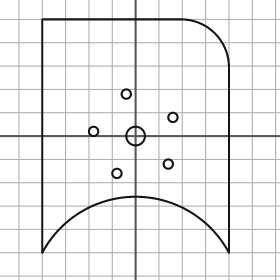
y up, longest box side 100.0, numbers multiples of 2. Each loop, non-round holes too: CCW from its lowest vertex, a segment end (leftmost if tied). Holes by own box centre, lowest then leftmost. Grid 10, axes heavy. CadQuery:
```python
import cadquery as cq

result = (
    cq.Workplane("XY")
    .moveTo(-40.0, -50.0)
    .threePointArc((0.0, -26.0), (40.0, -50.0))
    .lineTo(40.0, 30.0)
    .threePointArc((34.0, 44.0), (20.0, 50.0))
    .lineTo(-40.0, 50.0)
    .close()
    .moveTo(-8.0, -16.0)
    .circle(2.0)
    .moveTo(14.0, -12.0)
    .circle(2.0)
    .moveTo(0.0, 0.0)
    .circle(4.0)
    .moveTo(-18.0, 2.0)
    .circle(2.0)
    .moveTo(16.0, 8.0)
    .circle(2.0)
    .moveTo(-4.0, 18.0)
    .circle(2.0)
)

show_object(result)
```